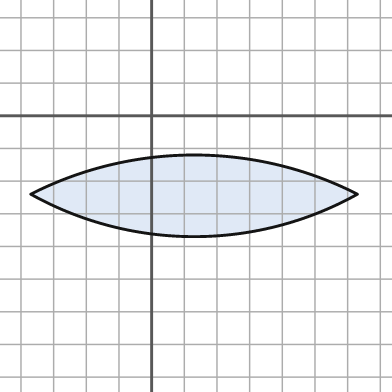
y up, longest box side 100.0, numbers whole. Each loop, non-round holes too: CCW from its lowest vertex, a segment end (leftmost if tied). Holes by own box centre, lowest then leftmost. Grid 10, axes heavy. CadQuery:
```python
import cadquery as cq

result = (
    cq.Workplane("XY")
    .moveTo(-37.0, -24.0)
    .threePointArc((13.0, -37.0), (63.0, -24.0))
    .threePointArc((13.0, -12.0), (-37.0, -24.0))
    .close()
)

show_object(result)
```